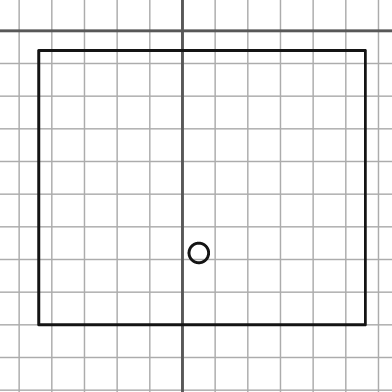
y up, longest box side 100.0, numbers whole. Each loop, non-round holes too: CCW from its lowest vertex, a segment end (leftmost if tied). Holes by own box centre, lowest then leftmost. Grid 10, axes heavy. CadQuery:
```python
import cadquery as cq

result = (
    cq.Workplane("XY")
    .moveTo(-44.0, -90.0)
    .lineTo(56.0, -90.0)
    .lineTo(56.0, -6.0)
    .lineTo(-44.0, -6.0)
    .close()
    .moveTo(5.0, -68.0)
    .circle(3.0)
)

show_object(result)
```